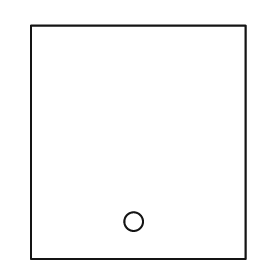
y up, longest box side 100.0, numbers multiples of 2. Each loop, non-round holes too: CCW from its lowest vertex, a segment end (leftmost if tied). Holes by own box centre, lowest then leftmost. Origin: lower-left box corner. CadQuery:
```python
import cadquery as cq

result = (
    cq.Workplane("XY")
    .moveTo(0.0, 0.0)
    .lineTo(92.0, 0.0)
    .lineTo(92.0, 100.0)
    .lineTo(0.0, 100.0)
    .close()
    .moveTo(44.0, 16.0)
    .circle(4.0)
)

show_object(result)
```